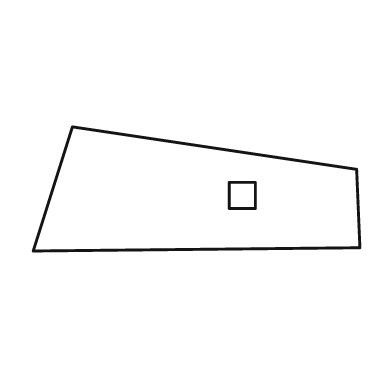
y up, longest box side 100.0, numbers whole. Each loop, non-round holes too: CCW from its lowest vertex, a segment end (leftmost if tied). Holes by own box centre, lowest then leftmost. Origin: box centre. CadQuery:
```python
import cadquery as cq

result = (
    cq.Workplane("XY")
    .moveTo(-50.0, -19.0)
    .lineTo(50.0, -18.0)
    .lineTo(49.0, 6.0)
    .lineTo(-38.0, 19.0)
    .close()
    .moveTo(10.0, -6.0)
    .lineTo(18.0, -6.0)
    .lineTo(18.0, 2.0)
    .lineTo(10.0, 2.0)
    .close()
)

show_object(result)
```